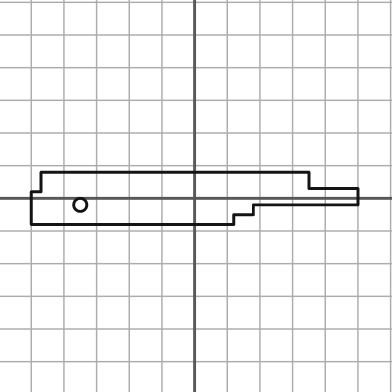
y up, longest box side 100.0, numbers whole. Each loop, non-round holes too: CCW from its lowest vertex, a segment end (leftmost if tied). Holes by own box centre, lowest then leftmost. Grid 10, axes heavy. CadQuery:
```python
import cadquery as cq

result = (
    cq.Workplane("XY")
    .moveTo(-50.0, -8.0)
    .lineTo(12.0, -8.0)
    .lineTo(12.0, -5.0)
    .lineTo(18.0, -5.0)
    .lineTo(18.0, -2.0)
    .lineTo(50.0, -2.0)
    .lineTo(50.0, 3.0)
    .lineTo(35.0, 3.0)
    .lineTo(35.0, 8.0)
    .lineTo(-47.0, 8.0)
    .lineTo(-47.0, 2.0)
    .lineTo(-50.0, 2.0)
    .close()
    .moveTo(-35.0, -2.0)
    .circle(2.0)
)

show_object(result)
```